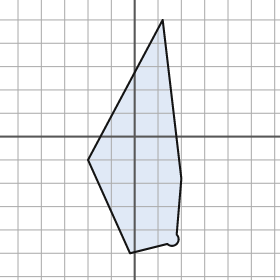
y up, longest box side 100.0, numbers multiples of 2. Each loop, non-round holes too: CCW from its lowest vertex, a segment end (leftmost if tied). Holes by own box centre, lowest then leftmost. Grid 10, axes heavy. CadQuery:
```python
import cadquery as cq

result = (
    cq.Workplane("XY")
    .moveTo(-2.0, -50.0)
    .lineTo(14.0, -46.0)
    .threePointArc((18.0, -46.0), (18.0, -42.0))
    .lineTo(20.0, -18.0)
    .lineTo(12.0, 50.0)
    .lineTo(-20.0, -10.0)
    .close()
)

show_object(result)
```